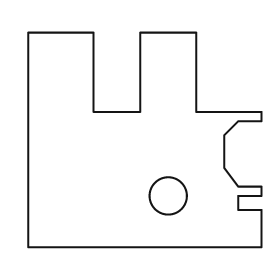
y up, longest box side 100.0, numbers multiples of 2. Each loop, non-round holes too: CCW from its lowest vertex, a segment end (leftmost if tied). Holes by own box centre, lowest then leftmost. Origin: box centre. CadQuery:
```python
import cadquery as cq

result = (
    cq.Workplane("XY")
    .moveTo(-50.0, -46.0)
    .lineTo(50.0, -46.0)
    .lineTo(50.0, -30.0)
    .lineTo(40.0, -30.0)
    .lineTo(40.0, -24.0)
    .lineTo(50.0, -24.0)
    .lineTo(50.0, -20.0)
    .lineTo(40.0, -20.0)
    .lineTo(34.0, -12.0)
    .lineTo(34.0, 2.0)
    .lineTo(40.0, 8.0)
    .lineTo(50.0, 8.0)
    .lineTo(50.0, 12.0)
    .lineTo(22.0, 12.0)
    .lineTo(22.0, 46.0)
    .lineTo(-2.0, 46.0)
    .lineTo(-2.0, 12.0)
    .lineTo(-22.0, 12.0)
    .lineTo(-22.0, 46.0)
    .lineTo(-50.0, 46.0)
    .close()
    .moveTo(10.0, -24.0)
    .circle(8.0)
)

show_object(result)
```